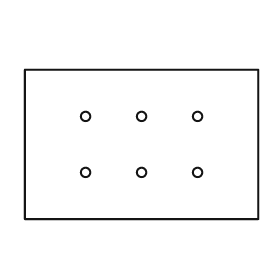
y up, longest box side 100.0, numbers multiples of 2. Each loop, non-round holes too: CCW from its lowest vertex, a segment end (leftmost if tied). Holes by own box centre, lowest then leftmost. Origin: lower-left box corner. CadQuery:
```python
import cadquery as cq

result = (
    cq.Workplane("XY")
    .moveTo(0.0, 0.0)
    .lineTo(100.0, 0.0)
    .lineTo(100.0, 64.0)
    .lineTo(0.0, 64.0)
    .close()
    .moveTo(26.0, 20.0)
    .circle(2.0)
    .moveTo(50.0, 20.0)
    .circle(2.0)
    .moveTo(74.0, 20.0)
    .circle(2.0)
    .moveTo(26.0, 44.0)
    .circle(2.0)
    .moveTo(50.0, 44.0)
    .circle(2.0)
    .moveTo(74.0, 44.0)
    .circle(2.0)
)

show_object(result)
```